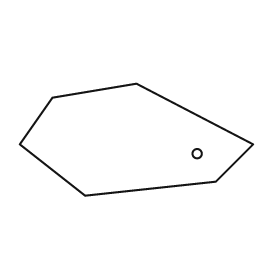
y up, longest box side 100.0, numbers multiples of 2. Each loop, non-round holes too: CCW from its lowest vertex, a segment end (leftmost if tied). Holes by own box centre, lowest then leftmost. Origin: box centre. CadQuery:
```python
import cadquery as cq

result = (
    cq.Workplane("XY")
    .moveTo(-22.0, -24.0)
    .lineTo(34.0, -18.0)
    .lineTo(50.0, -2.0)
    .lineTo(0.0, 24.0)
    .lineTo(-36.0, 18.0)
    .lineTo(-50.0, -2.0)
    .close()
    .moveTo(26.0, -6.0)
    .circle(2.0)
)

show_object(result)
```